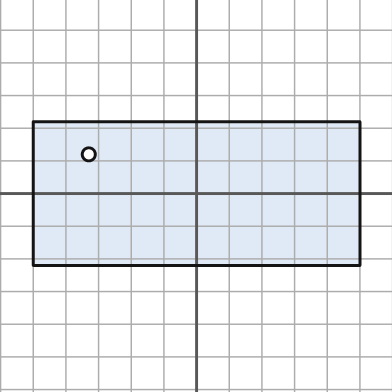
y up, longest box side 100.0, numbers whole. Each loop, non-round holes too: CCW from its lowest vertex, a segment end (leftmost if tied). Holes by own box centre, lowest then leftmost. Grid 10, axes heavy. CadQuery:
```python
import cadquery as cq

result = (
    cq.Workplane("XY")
    .moveTo(-50.0, -22.0)
    .lineTo(50.0, -22.0)
    .lineTo(50.0, 22.0)
    .lineTo(-50.0, 22.0)
    .close()
    .moveTo(-33.0, 12.0)
    .circle(2.0)
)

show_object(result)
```